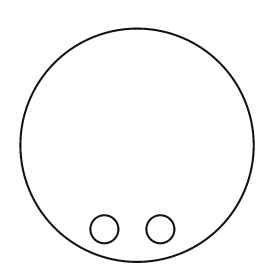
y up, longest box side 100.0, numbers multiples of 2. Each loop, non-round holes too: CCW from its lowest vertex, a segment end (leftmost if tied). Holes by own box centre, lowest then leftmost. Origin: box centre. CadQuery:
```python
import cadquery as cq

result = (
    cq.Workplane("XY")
    .moveTo(0.0, 0.0)
    .circle(50.0)
    .moveTo(-14.0, -36.0)
    .circle(6.0)
    .moveTo(10.0, -36.0)
    .circle(6.0)
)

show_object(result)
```